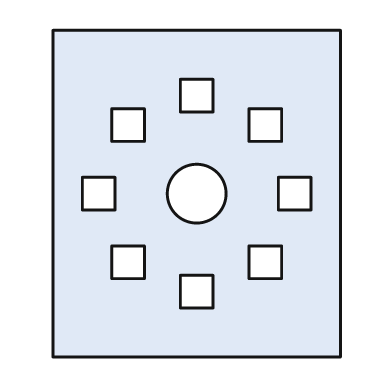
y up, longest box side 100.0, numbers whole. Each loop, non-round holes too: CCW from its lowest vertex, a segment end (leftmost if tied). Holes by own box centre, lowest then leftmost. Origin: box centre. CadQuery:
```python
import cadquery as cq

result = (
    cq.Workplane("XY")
    .moveTo(-44.0, -50.0)
    .lineTo(44.0, -50.0)
    .lineTo(44.0, 50.0)
    .lineTo(-44.0, 50.0)
    .close()
    .moveTo(-5.0, -35.0)
    .lineTo(5.0, -35.0)
    .lineTo(5.0, -25.0)
    .lineTo(-5.0, -25.0)
    .close()
    .moveTo(-26.0, -26.0)
    .lineTo(-16.0, -26.0)
    .lineTo(-16.0, -16.0)
    .lineTo(-26.0, -16.0)
    .close()
    .moveTo(16.0, -26.0)
    .lineTo(26.0, -26.0)
    .lineTo(26.0, -16.0)
    .lineTo(16.0, -16.0)
    .close()
    .moveTo(-35.0, -5.0)
    .lineTo(-25.0, -5.0)
    .lineTo(-25.0, 5.0)
    .lineTo(-35.0, 5.0)
    .close()
    .moveTo(0.0, 0.0)
    .circle(9.0)
    .moveTo(25.0, -5.0)
    .lineTo(35.0, -5.0)
    .lineTo(35.0, 5.0)
    .lineTo(25.0, 5.0)
    .close()
    .moveTo(-26.0, 16.0)
    .lineTo(-16.0, 16.0)
    .lineTo(-16.0, 26.0)
    .lineTo(-26.0, 26.0)
    .close()
    .moveTo(16.0, 16.0)
    .lineTo(26.0, 16.0)
    .lineTo(26.0, 26.0)
    .lineTo(16.0, 26.0)
    .close()
    .moveTo(-5.0, 25.0)
    .lineTo(5.0, 25.0)
    .lineTo(5.0, 35.0)
    .lineTo(-5.0, 35.0)
    .close()
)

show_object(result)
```